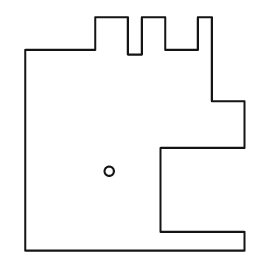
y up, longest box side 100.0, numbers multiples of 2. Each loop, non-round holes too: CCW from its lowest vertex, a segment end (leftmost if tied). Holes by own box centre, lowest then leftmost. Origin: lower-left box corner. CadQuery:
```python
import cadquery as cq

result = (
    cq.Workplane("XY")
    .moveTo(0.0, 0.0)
    .lineTo(94.0, 0.0)
    .lineTo(94.0, 8.0)
    .lineTo(58.0, 8.0)
    .lineTo(58.0, 44.0)
    .lineTo(94.0, 44.0)
    .lineTo(94.0, 64.0)
    .lineTo(80.0, 64.0)
    .lineTo(80.0, 100.0)
    .lineTo(74.0, 100.0)
    .lineTo(74.0, 86.0)
    .lineTo(60.0, 86.0)
    .lineTo(60.0, 100.0)
    .lineTo(50.0, 100.0)
    .lineTo(50.0, 84.0)
    .lineTo(44.0, 84.0)
    .lineTo(44.0, 100.0)
    .lineTo(30.0, 100.0)
    .lineTo(30.0, 86.0)
    .lineTo(0.0, 86.0)
    .close()
    .moveTo(36.0, 34.0)
    .circle(2.0)
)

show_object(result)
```